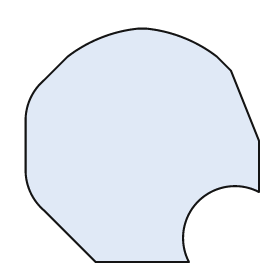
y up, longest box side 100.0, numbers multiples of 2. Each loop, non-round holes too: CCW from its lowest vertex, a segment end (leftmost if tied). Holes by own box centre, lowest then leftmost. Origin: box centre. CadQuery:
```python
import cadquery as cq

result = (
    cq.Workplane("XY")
    .moveTo(-20.0, -50.0)
    .lineTo(20.0, -50.0)
    .threePointArc((24.0, -24.0), (50.0, -20.0))
    .lineTo(50.0, 2.0)
    .lineTo(38.0, 32.0)
    .lineTo(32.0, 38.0)
    .threePointArc((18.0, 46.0), (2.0, 50.0))
    .lineTo(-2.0, 50.0)
    .threePointArc((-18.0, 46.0), (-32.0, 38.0))
    .lineTo(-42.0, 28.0)
    .threePointArc((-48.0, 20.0), (-50.0, 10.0))
    .lineTo(-50.0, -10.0)
    .threePointArc((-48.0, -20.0), (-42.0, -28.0))
    .close()
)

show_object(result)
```